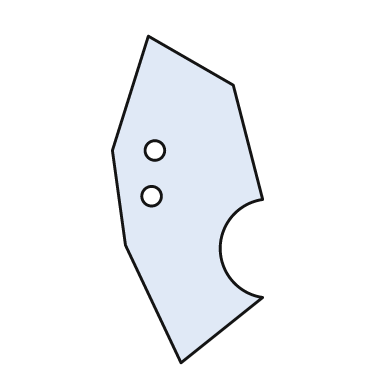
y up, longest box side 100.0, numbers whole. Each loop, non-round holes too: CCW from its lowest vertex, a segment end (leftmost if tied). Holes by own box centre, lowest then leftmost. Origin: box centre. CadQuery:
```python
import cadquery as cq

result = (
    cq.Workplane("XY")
    .moveTo(-2.0, -50.0)
    .lineTo(23.0, -30.0)
    .threePointArc((10.0, -15.0), (23.0, 0.0))
    .lineTo(14.0, 35.0)
    .lineTo(-12.0, 50.0)
    .lineTo(-23.0, 15.0)
    .lineTo(-19.0, -14.0)
    .close()
    .moveTo(-11.0, 1.0)
    .circle(3.0)
    .moveTo(-10.0, 15.0)
    .circle(3.0)
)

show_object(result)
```